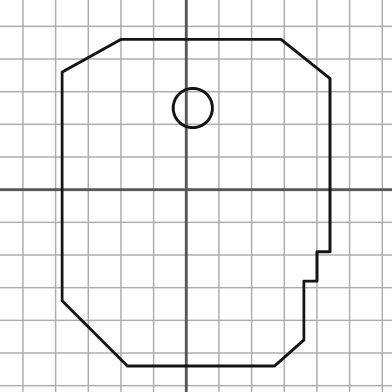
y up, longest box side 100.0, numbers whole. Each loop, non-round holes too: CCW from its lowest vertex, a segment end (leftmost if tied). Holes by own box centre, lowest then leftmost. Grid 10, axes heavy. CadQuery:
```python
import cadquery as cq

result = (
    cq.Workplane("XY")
    .moveTo(-18.0, -54.0)
    .lineTo(27.0, -54.0)
    .lineTo(36.0, -46.0)
    .lineTo(36.0, -28.0)
    .lineTo(40.0, -28.0)
    .lineTo(40.0, -19.0)
    .lineTo(44.0, -19.0)
    .lineTo(44.0, 34.0)
    .lineTo(29.0, 46.0)
    .lineTo(-20.0, 46.0)
    .lineTo(-38.0, 36.0)
    .lineTo(-38.0, -34.0)
    .close()
    .moveTo(2.0, 25.0)
    .circle(6.0)
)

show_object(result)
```